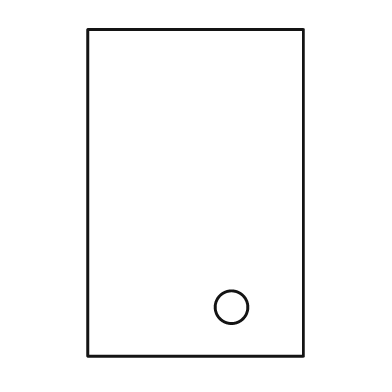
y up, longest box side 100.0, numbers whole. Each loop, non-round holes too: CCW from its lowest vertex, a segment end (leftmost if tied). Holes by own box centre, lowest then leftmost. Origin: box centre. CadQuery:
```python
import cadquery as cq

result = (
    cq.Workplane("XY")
    .moveTo(-33.0, -50.0)
    .lineTo(33.0, -50.0)
    .lineTo(33.0, 50.0)
    .lineTo(-33.0, 50.0)
    .close()
    .moveTo(11.0, -35.0)
    .circle(5.0)
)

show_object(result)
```